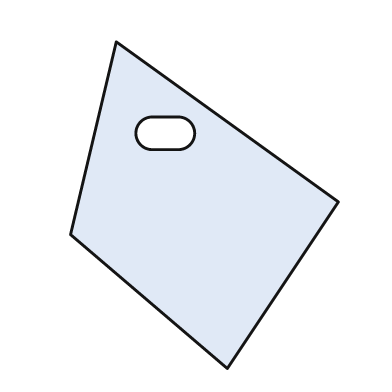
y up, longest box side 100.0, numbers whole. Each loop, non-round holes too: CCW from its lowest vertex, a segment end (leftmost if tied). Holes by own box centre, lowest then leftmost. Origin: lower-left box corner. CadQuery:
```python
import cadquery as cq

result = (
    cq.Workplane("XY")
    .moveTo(48.0, 0.0)
    .lineTo(82.0, 51.0)
    .lineTo(14.0, 100.0)
    .lineTo(0.0, 41.0)
    .close()
    .moveTo(25.0, 67.0)
    .lineTo(33.0, 67.0)
    .threePointArc((38.0, 72.0), (33.0, 77.0))
    .lineTo(25.0, 77.0)
    .threePointArc((20.0, 72.0), (25.0, 67.0))
    .close()
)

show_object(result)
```